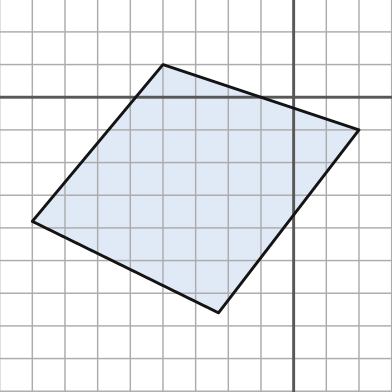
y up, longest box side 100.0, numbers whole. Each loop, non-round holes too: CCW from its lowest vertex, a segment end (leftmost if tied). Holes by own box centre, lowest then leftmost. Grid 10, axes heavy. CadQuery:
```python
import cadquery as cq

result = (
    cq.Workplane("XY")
    .moveTo(-23.0, -66.0)
    .lineTo(20.0, -10.0)
    .lineTo(-40.0, 10.0)
    .lineTo(-80.0, -38.0)
    .close()
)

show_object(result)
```